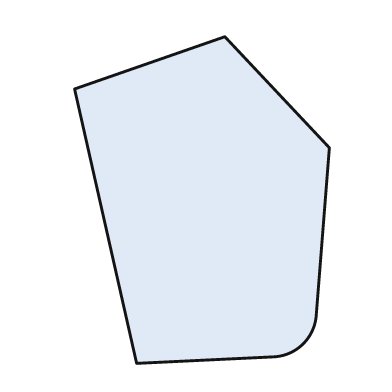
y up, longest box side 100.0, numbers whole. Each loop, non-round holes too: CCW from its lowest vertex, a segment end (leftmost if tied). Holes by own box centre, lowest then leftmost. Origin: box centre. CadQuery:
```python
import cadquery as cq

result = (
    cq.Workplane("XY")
    .moveTo(-20.0, -50.0)
    .lineTo(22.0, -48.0)
    .threePointArc((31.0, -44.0), (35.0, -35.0))
    .lineTo(39.0, 16.0)
    .lineTo(7.0, 50.0)
    .lineTo(-39.0, 34.0)
    .close()
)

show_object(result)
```